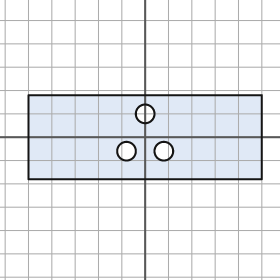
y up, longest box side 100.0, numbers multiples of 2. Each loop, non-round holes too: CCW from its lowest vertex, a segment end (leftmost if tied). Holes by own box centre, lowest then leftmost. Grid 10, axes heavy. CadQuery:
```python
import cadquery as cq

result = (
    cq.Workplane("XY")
    .moveTo(-50.0, -18.0)
    .lineTo(50.0, -18.0)
    .lineTo(50.0, 18.0)
    .lineTo(-50.0, 18.0)
    .close()
    .moveTo(-8.0, -6.0)
    .circle(4.0)
    .moveTo(8.0, -6.0)
    .circle(4.0)
    .moveTo(0.0, 10.0)
    .circle(4.0)
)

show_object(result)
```